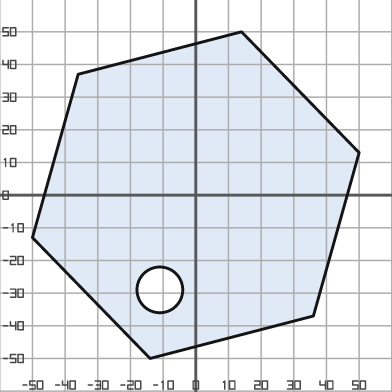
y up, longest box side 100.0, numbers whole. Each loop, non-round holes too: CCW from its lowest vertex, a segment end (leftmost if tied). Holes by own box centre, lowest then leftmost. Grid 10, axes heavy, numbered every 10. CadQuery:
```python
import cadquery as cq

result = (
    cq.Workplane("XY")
    .moveTo(-14.0, -50.0)
    .lineTo(36.0, -37.0)
    .lineTo(50.0, 13.0)
    .lineTo(14.0, 50.0)
    .lineTo(-36.0, 37.0)
    .lineTo(-50.0, -13.0)
    .close()
    .moveTo(-11.0, -29.0)
    .circle(7.0)
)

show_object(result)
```